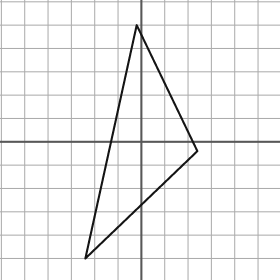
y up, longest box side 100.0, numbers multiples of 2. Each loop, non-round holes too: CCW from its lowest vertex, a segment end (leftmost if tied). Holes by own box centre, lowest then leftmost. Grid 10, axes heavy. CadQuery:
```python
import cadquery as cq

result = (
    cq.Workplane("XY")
    .moveTo(-24.0, -50.0)
    .lineTo(24.0, -4.0)
    .lineTo(-2.0, 50.0)
    .close()
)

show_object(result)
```